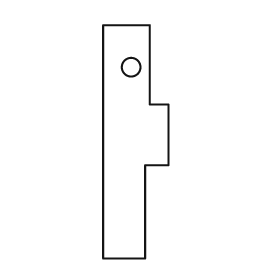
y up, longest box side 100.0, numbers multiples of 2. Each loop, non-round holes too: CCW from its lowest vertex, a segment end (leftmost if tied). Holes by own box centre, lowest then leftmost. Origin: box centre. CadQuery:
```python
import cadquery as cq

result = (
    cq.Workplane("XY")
    .moveTo(-14.0, -50.0)
    .lineTo(4.0, -50.0)
    .lineTo(4.0, -10.0)
    .lineTo(14.0, -10.0)
    .lineTo(14.0, 16.0)
    .lineTo(6.0, 16.0)
    .lineTo(6.0, 50.0)
    .lineTo(-14.0, 50.0)
    .close()
    .moveTo(-2.0, 32.0)
    .circle(4.0)
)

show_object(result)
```